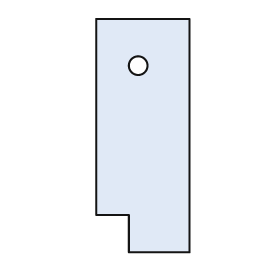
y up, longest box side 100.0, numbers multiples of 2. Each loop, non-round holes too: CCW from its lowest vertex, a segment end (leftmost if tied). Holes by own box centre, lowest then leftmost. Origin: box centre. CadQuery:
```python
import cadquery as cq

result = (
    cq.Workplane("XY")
    .moveTo(-6.0, -50.0)
    .lineTo(20.0, -50.0)
    .lineTo(20.0, 50.0)
    .lineTo(-20.0, 50.0)
    .lineTo(-20.0, -34.0)
    .lineTo(-6.0, -34.0)
    .close()
    .moveTo(-2.0, 30.0)
    .circle(4.0)
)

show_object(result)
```